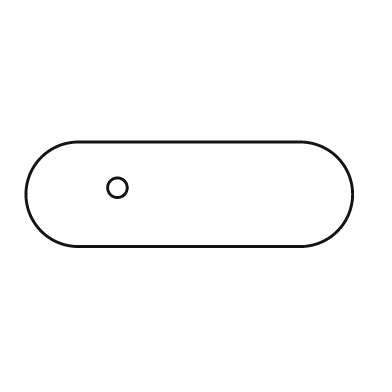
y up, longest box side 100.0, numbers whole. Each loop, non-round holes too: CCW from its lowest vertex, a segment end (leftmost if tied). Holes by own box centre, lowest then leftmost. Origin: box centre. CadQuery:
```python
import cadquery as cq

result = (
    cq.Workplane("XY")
    .moveTo(-34.0, -16.0)
    .lineTo(34.0, -16.0)
    .threePointArc((50.0, 0.0), (34.0, 16.0))
    .lineTo(-34.0, 16.0)
    .threePointArc((-50.0, 0.0), (-34.0, -16.0))
    .close()
    .moveTo(-22.0, 2.0)
    .circle(3.0)
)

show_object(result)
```